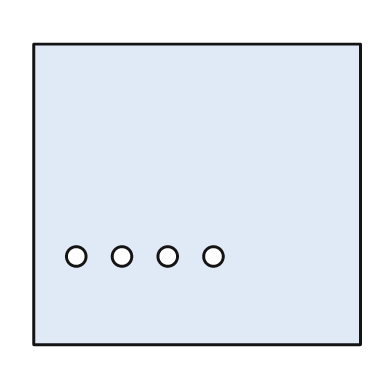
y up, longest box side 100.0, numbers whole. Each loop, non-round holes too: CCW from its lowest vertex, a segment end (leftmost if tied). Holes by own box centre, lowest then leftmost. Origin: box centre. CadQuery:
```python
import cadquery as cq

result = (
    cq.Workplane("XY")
    .moveTo(-50.0, -46.0)
    .lineTo(50.0, -46.0)
    .lineTo(50.0, 46.0)
    .lineTo(-50.0, 46.0)
    .close()
    .moveTo(-37.0, -19.0)
    .circle(3.0)
    .moveTo(-23.0, -19.0)
    .circle(3.0)
    .moveTo(-9.0, -19.0)
    .circle(3.0)
    .moveTo(5.0, -19.0)
    .circle(3.0)
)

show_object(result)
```